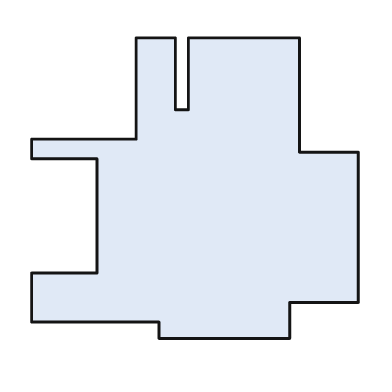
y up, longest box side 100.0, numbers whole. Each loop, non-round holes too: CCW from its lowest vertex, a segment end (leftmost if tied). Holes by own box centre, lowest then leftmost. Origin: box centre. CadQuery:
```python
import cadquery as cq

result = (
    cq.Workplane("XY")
    .moveTo(-11.0, -46.0)
    .lineTo(29.0, -46.0)
    .lineTo(29.0, -35.0)
    .lineTo(50.0, -35.0)
    .lineTo(50.0, 11.0)
    .lineTo(32.0, 11.0)
    .lineTo(32.0, 46.0)
    .lineTo(-2.0, 46.0)
    .lineTo(-2.0, 24.0)
    .lineTo(-6.0, 24.0)
    .lineTo(-6.0, 46.0)
    .lineTo(-18.0, 46.0)
    .lineTo(-18.0, 15.0)
    .lineTo(-50.0, 15.0)
    .lineTo(-50.0, 9.0)
    .lineTo(-30.0, 9.0)
    .lineTo(-30.0, -26.0)
    .lineTo(-50.0, -26.0)
    .lineTo(-50.0, -41.0)
    .lineTo(-11.0, -41.0)
    .close()
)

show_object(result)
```